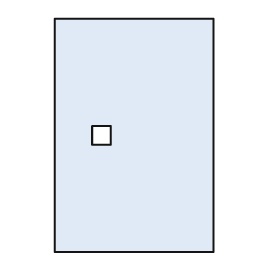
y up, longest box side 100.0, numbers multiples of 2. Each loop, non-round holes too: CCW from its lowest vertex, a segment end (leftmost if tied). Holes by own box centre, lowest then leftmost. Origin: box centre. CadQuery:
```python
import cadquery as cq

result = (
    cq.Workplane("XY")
    .moveTo(-34.0, -50.0)
    .lineTo(34.0, -50.0)
    .lineTo(34.0, 50.0)
    .lineTo(-34.0, 50.0)
    .close()
    .moveTo(-18.0, -4.0)
    .lineTo(-10.0, -4.0)
    .lineTo(-10.0, 4.0)
    .lineTo(-18.0, 4.0)
    .close()
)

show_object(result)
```